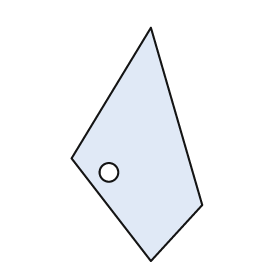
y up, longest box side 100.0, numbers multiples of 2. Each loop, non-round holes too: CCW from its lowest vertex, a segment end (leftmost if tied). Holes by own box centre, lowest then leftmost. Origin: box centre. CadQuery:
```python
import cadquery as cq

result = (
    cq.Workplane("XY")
    .moveTo(6.0, -50.0)
    .lineTo(28.0, -26.0)
    .lineTo(6.0, 50.0)
    .lineTo(-28.0, -6.0)
    .close()
    .moveTo(-12.0, -12.0)
    .circle(4.0)
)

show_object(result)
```